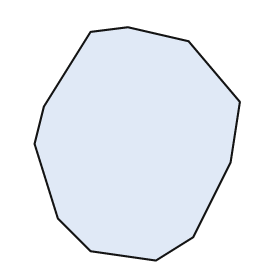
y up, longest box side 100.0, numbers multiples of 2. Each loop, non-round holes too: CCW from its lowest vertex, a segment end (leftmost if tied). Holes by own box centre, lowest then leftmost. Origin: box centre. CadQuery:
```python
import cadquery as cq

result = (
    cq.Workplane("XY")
    .moveTo(8.0, -50.0)
    .lineTo(24.0, -40.0)
    .lineTo(40.0, -8.0)
    .lineTo(44.0, 18.0)
    .lineTo(22.0, 44.0)
    .lineTo(-4.0, 50.0)
    .lineTo(-20.0, 48.0)
    .lineTo(-40.0, 16.0)
    .lineTo(-44.0, 0.0)
    .lineTo(-34.0, -32.0)
    .lineTo(-20.0, -46.0)
    .close()
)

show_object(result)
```